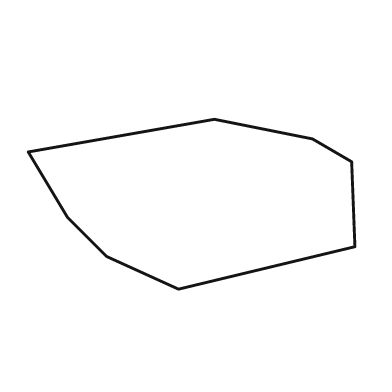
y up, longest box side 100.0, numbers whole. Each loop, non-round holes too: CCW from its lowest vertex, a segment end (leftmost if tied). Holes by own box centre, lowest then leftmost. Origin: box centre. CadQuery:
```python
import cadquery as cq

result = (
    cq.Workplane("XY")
    .moveTo(-4.0, -26.0)
    .lineTo(50.0, -13.0)
    .lineTo(49.0, 13.0)
    .lineTo(37.0, 20.0)
    .lineTo(7.0, 26.0)
    .lineTo(-50.0, 16.0)
    .lineTo(-38.0, -4.0)
    .lineTo(-26.0, -16.0)
    .close()
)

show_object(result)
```